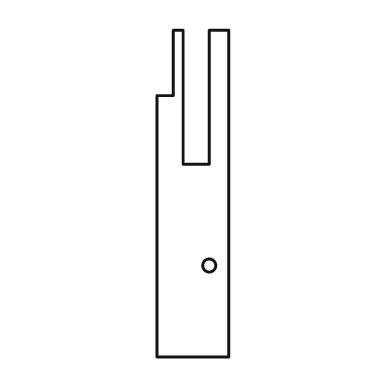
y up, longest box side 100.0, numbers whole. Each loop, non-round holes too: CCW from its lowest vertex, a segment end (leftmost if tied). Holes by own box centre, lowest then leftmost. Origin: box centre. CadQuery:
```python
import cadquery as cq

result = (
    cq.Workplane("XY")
    .moveTo(-11.0, -50.0)
    .lineTo(11.0, -50.0)
    .lineTo(11.0, 50.0)
    .lineTo(5.0, 50.0)
    .lineTo(5.0, 9.0)
    .lineTo(-3.0, 9.0)
    .lineTo(-3.0, 50.0)
    .lineTo(-6.0, 50.0)
    .lineTo(-6.0, 30.0)
    .lineTo(-11.0, 30.0)
    .close()
    .moveTo(5.0, -22.0)
    .circle(2.0)
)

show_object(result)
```